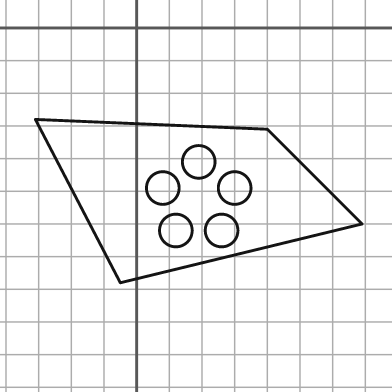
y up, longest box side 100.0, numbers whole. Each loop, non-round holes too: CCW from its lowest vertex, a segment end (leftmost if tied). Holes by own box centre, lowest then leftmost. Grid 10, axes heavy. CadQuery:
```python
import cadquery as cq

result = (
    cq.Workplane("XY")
    .moveTo(-5.0, -78.0)
    .lineTo(69.0, -60.0)
    .lineTo(40.0, -31.0)
    .lineTo(-31.0, -28.0)
    .close()
    .moveTo(12.0, -62.0)
    .circle(5.0)
    .moveTo(26.0, -62.0)
    .circle(5.0)
    .moveTo(8.0, -49.0)
    .circle(5.0)
    .moveTo(30.0, -49.0)
    .circle(5.0)
    .moveTo(19.0, -41.0)
    .circle(5.0)
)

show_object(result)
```